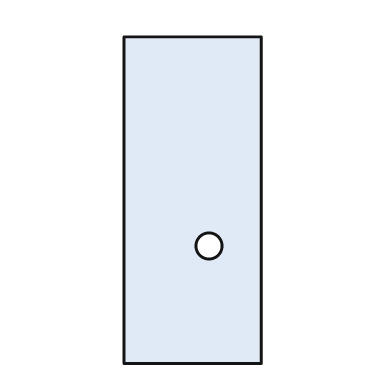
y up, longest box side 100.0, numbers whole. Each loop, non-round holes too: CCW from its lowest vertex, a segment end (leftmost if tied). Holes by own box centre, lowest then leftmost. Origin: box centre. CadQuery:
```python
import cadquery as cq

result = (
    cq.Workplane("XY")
    .moveTo(-21.0, -50.0)
    .lineTo(21.0, -50.0)
    .lineTo(21.0, 50.0)
    .lineTo(-21.0, 50.0)
    .close()
    .moveTo(5.0, -14.0)
    .circle(4.0)
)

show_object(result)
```